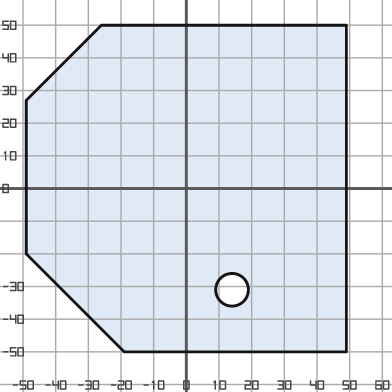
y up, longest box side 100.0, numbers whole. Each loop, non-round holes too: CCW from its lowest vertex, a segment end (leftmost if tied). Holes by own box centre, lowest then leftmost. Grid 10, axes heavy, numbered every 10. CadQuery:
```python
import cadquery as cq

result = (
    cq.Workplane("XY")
    .moveTo(-19.0, -50.0)
    .lineTo(49.0, -50.0)
    .lineTo(49.0, 50.0)
    .lineTo(-26.0, 50.0)
    .lineTo(-49.0, 27.0)
    .lineTo(-49.0, -20.0)
    .close()
    .moveTo(14.0, -31.0)
    .circle(5.0)
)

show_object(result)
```